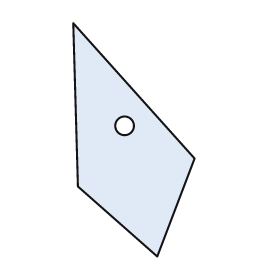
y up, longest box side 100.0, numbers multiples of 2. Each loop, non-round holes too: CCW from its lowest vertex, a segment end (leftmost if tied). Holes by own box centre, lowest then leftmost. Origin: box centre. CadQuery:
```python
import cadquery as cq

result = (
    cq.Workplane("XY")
    .moveTo(10.0, -50.0)
    .lineTo(26.0, -8.0)
    .lineTo(-26.0, 50.0)
    .lineTo(-24.0, -20.0)
    .close()
    .moveTo(-4.0, 6.0)
    .circle(4.0)
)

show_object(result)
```